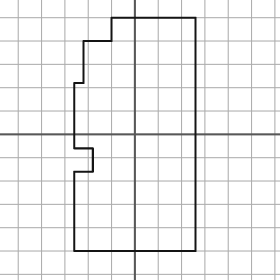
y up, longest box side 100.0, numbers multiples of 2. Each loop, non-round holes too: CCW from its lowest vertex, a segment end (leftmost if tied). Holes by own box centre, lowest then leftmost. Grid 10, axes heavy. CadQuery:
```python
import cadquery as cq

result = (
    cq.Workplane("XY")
    .moveTo(-26.0, -50.0)
    .lineTo(26.0, -50.0)
    .lineTo(26.0, 50.0)
    .lineTo(-10.0, 50.0)
    .lineTo(-10.0, 40.0)
    .lineTo(-22.0, 40.0)
    .lineTo(-22.0, 22.0)
    .lineTo(-26.0, 22.0)
    .lineTo(-26.0, -6.0)
    .lineTo(-18.0, -6.0)
    .lineTo(-18.0, -16.0)
    .lineTo(-26.0, -16.0)
    .close()
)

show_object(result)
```